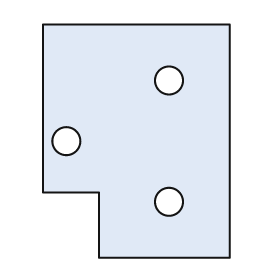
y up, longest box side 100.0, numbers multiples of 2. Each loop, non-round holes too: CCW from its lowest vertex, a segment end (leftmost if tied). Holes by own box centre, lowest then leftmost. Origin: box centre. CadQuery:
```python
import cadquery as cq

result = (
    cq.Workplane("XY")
    .moveTo(-16.0, -50.0)
    .lineTo(40.0, -50.0)
    .lineTo(40.0, 50.0)
    .lineTo(-40.0, 50.0)
    .lineTo(-40.0, -22.0)
    .lineTo(-16.0, -22.0)
    .close()
    .moveTo(14.0, -26.0)
    .circle(6.0)
    .moveTo(-30.0, 0.0)
    .circle(6.0)
    .moveTo(14.0, 26.0)
    .circle(6.0)
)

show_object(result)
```